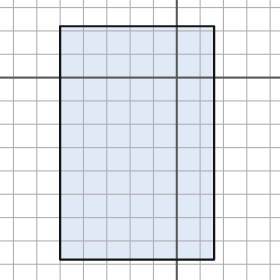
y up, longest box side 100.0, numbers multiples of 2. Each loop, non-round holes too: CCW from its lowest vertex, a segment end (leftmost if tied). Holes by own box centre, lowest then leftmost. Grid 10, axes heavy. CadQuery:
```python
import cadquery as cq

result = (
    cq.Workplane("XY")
    .moveTo(-50.0, -78.0)
    .lineTo(16.0, -78.0)
    .lineTo(16.0, 22.0)
    .lineTo(-50.0, 22.0)
    .close()
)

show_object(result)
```